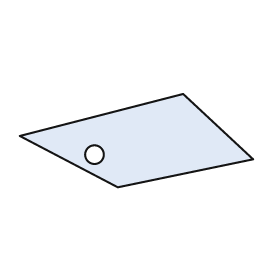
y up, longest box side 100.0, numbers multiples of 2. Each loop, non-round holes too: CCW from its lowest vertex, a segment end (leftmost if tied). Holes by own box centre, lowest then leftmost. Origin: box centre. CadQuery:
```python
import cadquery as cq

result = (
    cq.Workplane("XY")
    .moveTo(-8.0, -20.0)
    .lineTo(50.0, -8.0)
    .lineTo(20.0, 20.0)
    .lineTo(-50.0, 2.0)
    .close()
    .moveTo(-18.0, -6.0)
    .circle(4.0)
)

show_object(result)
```